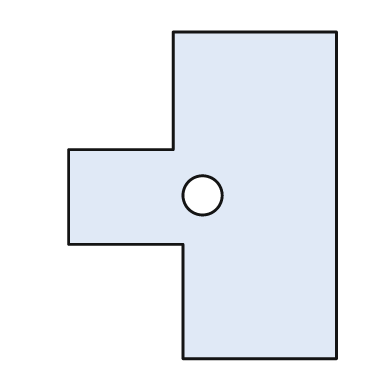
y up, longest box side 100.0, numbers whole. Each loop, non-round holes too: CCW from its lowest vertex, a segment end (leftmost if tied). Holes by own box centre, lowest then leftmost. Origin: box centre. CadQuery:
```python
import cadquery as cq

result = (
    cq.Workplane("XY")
    .moveTo(-6.0, -50.0)
    .lineTo(41.0, -50.0)
    .lineTo(41.0, 50.0)
    .lineTo(-9.0, 50.0)
    .lineTo(-9.0, 14.0)
    .lineTo(-41.0, 14.0)
    .lineTo(-41.0, -15.0)
    .lineTo(-6.0, -15.0)
    .close()
    .moveTo(0.0, 0.0)
    .circle(6.0)
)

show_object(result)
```